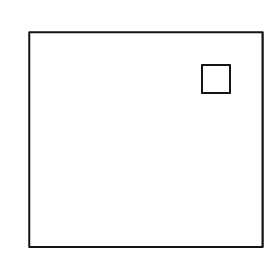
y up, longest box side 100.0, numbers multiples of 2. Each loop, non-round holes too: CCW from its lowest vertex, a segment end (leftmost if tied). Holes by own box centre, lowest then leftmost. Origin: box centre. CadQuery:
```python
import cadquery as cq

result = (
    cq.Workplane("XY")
    .moveTo(-50.0, -46.0)
    .lineTo(50.0, -46.0)
    .lineTo(50.0, 46.0)
    .lineTo(-50.0, 46.0)
    .close()
    .moveTo(24.0, 20.0)
    .lineTo(36.0, 20.0)
    .lineTo(36.0, 32.0)
    .lineTo(24.0, 32.0)
    .close()
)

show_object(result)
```